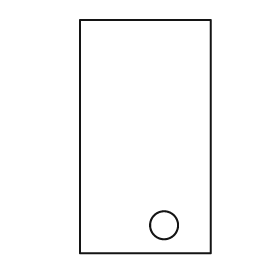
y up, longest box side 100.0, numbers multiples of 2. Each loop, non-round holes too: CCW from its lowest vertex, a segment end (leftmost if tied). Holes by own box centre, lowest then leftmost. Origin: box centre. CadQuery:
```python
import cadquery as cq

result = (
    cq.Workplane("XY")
    .moveTo(-28.0, -50.0)
    .lineTo(28.0, -50.0)
    .lineTo(28.0, 50.0)
    .lineTo(-28.0, 50.0)
    .close()
    .moveTo(8.0, -38.0)
    .circle(6.0)
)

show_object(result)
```